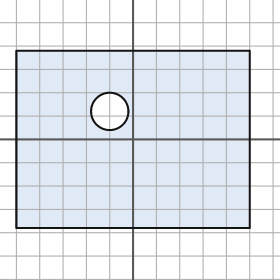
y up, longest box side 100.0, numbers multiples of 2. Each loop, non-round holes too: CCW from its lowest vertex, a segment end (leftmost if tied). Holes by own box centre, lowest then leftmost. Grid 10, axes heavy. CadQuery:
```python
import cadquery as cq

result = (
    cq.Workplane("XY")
    .moveTo(-50.0, -38.0)
    .lineTo(50.0, -38.0)
    .lineTo(50.0, 38.0)
    .lineTo(-50.0, 38.0)
    .close()
    .moveTo(-10.0, 12.0)
    .circle(8.0)
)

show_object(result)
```